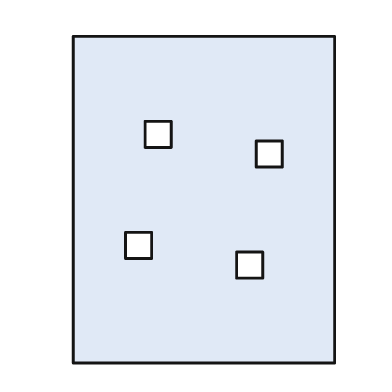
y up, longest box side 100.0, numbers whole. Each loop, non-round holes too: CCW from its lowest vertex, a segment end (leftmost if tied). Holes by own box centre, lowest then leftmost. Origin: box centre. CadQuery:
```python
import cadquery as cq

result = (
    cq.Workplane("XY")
    .moveTo(-40.0, -50.0)
    .lineTo(40.0, -50.0)
    .lineTo(40.0, 50.0)
    .lineTo(-40.0, 50.0)
    .close()
    .moveTo(10.0, -24.0)
    .lineTo(18.0, -24.0)
    .lineTo(18.0, -16.0)
    .lineTo(10.0, -16.0)
    .close()
    .moveTo(-24.0, -18.0)
    .lineTo(-16.0, -18.0)
    .lineTo(-16.0, -10.0)
    .lineTo(-24.0, -10.0)
    .close()
    .moveTo(16.0, 10.0)
    .lineTo(24.0, 10.0)
    .lineTo(24.0, 18.0)
    .lineTo(16.0, 18.0)
    .close()
    .moveTo(-18.0, 16.0)
    .lineTo(-10.0, 16.0)
    .lineTo(-10.0, 24.0)
    .lineTo(-18.0, 24.0)
    .close()
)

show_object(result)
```